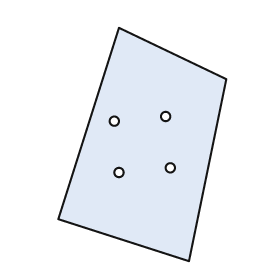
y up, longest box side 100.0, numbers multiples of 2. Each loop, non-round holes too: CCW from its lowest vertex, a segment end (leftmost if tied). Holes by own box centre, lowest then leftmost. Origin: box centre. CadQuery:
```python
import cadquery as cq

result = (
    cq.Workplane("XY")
    .moveTo(20.0, -50.0)
    .lineTo(36.0, 28.0)
    .lineTo(-10.0, 50.0)
    .lineTo(-36.0, -32.0)
    .close()
    .moveTo(-10.0, -12.0)
    .circle(2.0)
    .moveTo(12.0, -10.0)
    .circle(2.0)
    .moveTo(-12.0, 10.0)
    .circle(2.0)
    .moveTo(10.0, 12.0)
    .circle(2.0)
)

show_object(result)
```